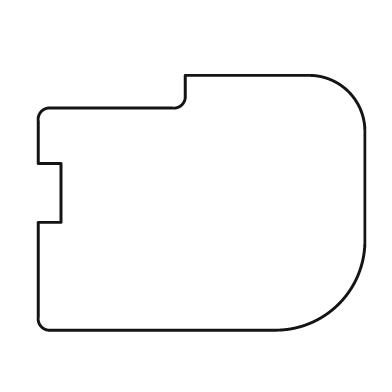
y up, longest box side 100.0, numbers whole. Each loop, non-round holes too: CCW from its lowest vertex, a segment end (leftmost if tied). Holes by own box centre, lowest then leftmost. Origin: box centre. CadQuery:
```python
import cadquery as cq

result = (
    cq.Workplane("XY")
    .moveTo(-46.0, -39.0)
    .lineTo(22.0, -39.0)
    .threePointArc((42.0, -31.0), (50.0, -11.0))
    .lineTo(50.0, 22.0)
    .threePointArc((45.0, 34.0), (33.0, 39.0))
    .lineTo(-5.0, 39.0)
    .lineTo(-5.0, 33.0)
    .threePointArc((-6.0, 30.0), (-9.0, 29.0))
    .lineTo(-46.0, 29.0)
    .threePointArc((-49.0, 28.0), (-50.0, 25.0))
    .lineTo(-50.0, 12.0)
    .lineTo(-43.0, 12.0)
    .lineTo(-43.0, -6.0)
    .lineTo(-50.0, -6.0)
    .lineTo(-50.0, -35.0)
    .threePointArc((-49.0, -38.0), (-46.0, -39.0))
    .close()
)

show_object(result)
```